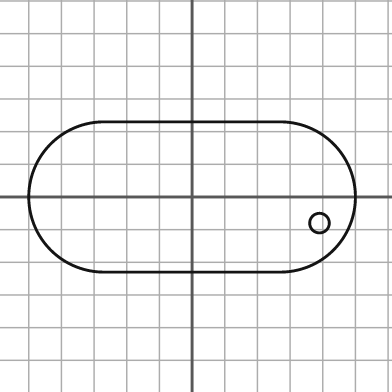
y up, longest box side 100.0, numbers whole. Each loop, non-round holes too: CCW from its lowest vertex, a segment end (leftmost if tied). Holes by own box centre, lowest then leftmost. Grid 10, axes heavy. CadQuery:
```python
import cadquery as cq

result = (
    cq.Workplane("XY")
    .moveTo(-27.0, -23.0)
    .lineTo(27.0, -23.0)
    .threePointArc((50.0, 0.0), (27.0, 23.0))
    .lineTo(-27.0, 23.0)
    .threePointArc((-50.0, 0.0), (-27.0, -23.0))
    .close()
    .moveTo(39.0, -8.0)
    .circle(3.0)
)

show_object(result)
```